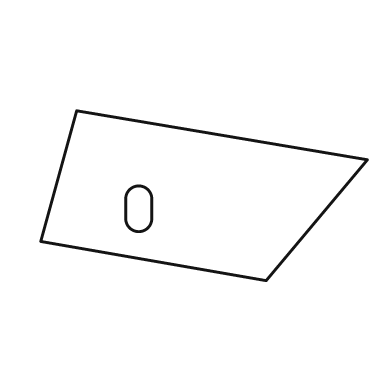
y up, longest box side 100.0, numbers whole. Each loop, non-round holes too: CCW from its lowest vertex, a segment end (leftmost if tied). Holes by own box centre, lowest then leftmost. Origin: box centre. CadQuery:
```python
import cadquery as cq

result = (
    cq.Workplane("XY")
    .moveTo(19.0, -26.0)
    .lineTo(50.0, 11.0)
    .lineTo(-39.0, 26.0)
    .lineTo(-50.0, -14.0)
    .close()
    .moveTo(-24.0, -7.0)
    .threePointArc((-20.0, -11.0), (-16.0, -7.0))
    .lineTo(-16.0, -1.0)
    .threePointArc((-20.0, 3.0), (-24.0, -1.0))
    .close()
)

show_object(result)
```